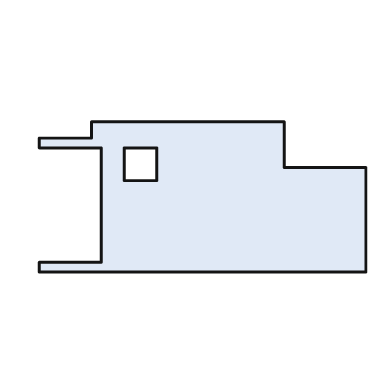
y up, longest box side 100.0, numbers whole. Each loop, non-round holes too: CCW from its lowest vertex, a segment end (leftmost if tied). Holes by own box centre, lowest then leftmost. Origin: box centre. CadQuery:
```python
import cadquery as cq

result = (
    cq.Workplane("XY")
    .moveTo(-50.0, -23.0)
    .lineTo(50.0, -23.0)
    .lineTo(50.0, 9.0)
    .lineTo(25.0, 9.0)
    .lineTo(25.0, 23.0)
    .lineTo(-34.0, 23.0)
    .lineTo(-34.0, 18.0)
    .lineTo(-50.0, 18.0)
    .lineTo(-50.0, 15.0)
    .lineTo(-31.0, 15.0)
    .lineTo(-31.0, -20.0)
    .lineTo(-50.0, -20.0)
    .close()
    .moveTo(-24.0, 5.0)
    .lineTo(-14.0, 5.0)
    .lineTo(-14.0, 15.0)
    .lineTo(-24.0, 15.0)
    .close()
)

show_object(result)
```